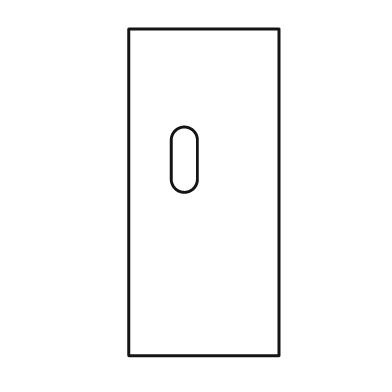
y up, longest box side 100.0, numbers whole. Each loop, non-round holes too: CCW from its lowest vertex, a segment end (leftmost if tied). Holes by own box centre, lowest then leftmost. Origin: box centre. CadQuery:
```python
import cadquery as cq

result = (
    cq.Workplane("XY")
    .moveTo(-23.0, -50.0)
    .lineTo(23.0, -50.0)
    .lineTo(23.0, 50.0)
    .lineTo(-23.0, 50.0)
    .close()
    .moveTo(-10.0, 4.0)
    .threePointArc((-6.0, 0.0), (-2.0, 4.0))
    .lineTo(-2.0, 16.0)
    .threePointArc((-6.0, 20.0), (-10.0, 16.0))
    .close()
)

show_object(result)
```